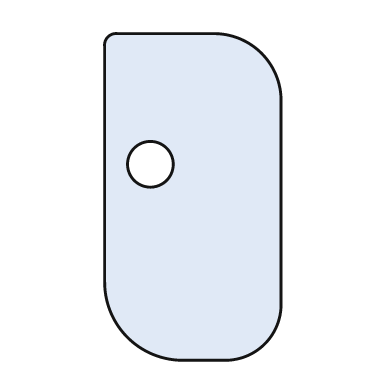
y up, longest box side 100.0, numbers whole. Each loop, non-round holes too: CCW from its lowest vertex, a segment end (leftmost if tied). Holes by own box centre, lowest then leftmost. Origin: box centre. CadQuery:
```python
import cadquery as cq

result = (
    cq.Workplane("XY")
    .moveTo(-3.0, -50.0)
    .lineTo(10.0, -50.0)
    .threePointArc((22.0, -45.0), (27.0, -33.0))
    .lineTo(27.0, 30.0)
    .threePointArc((21.0, 44.0), (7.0, 50.0))
    .lineTo(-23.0, 50.0)
    .threePointArc((-26.0, 49.0), (-27.0, 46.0))
    .lineTo(-27.0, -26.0)
    .threePointArc((-20.0, -43.0), (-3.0, -50.0))
    .close()
    .moveTo(-13.0, 10.0)
    .circle(7.0)
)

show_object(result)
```